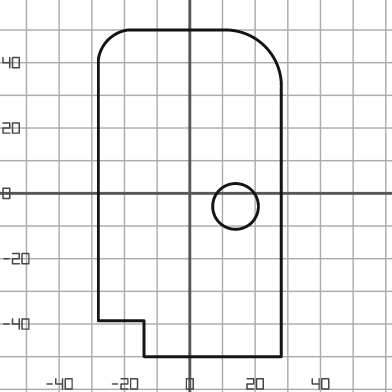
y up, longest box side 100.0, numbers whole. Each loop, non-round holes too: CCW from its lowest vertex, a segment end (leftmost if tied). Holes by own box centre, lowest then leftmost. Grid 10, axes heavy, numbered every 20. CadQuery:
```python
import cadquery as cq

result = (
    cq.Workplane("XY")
    .moveTo(-14.0, -50.0)
    .lineTo(28.0, -50.0)
    .lineTo(28.0, 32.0)
    .threePointArc((23.0, 45.0), (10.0, 50.0))
    .lineTo(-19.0, 50.0)
    .threePointArc((-25.0, 47.0), (-28.0, 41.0))
    .lineTo(-28.0, -39.0)
    .lineTo(-14.0, -39.0)
    .close()
    .moveTo(14.0, -4.0)
    .circle(7.0)
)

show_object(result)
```